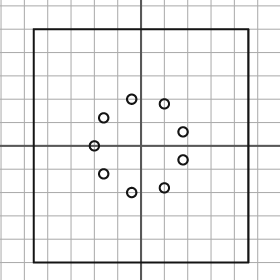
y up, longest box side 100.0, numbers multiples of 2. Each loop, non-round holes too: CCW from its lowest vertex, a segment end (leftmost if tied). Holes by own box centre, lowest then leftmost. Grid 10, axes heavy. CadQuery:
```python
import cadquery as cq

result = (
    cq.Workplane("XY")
    .moveTo(-46.0, -50.0)
    .lineTo(46.0, -50.0)
    .lineTo(46.0, 50.0)
    .lineTo(-46.0, 50.0)
    .close()
    .moveTo(-4.0, -20.0)
    .circle(2.0)
    .moveTo(10.0, -18.0)
    .circle(2.0)
    .moveTo(-16.0, -12.0)
    .circle(2.0)
    .moveTo(18.0, -6.0)
    .circle(2.0)
    .moveTo(-20.0, 0.0)
    .circle(2.0)
    .moveTo(18.0, 6.0)
    .circle(2.0)
    .moveTo(-16.0, 12.0)
    .circle(2.0)
    .moveTo(10.0, 18.0)
    .circle(2.0)
    .moveTo(-4.0, 20.0)
    .circle(2.0)
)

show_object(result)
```